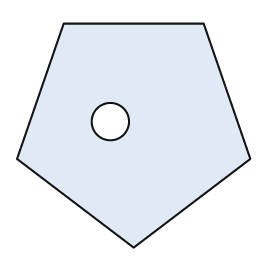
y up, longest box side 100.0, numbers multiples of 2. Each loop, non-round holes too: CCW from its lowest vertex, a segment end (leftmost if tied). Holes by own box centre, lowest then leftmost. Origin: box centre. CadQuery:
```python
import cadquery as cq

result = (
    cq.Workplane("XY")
    .moveTo(0.0, -48.0)
    .lineTo(50.0, -10.0)
    .lineTo(30.0, 48.0)
    .lineTo(-30.0, 48.0)
    .lineTo(-50.0, -10.0)
    .close()
    .moveTo(-10.0, 6.0)
    .circle(8.0)
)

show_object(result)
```